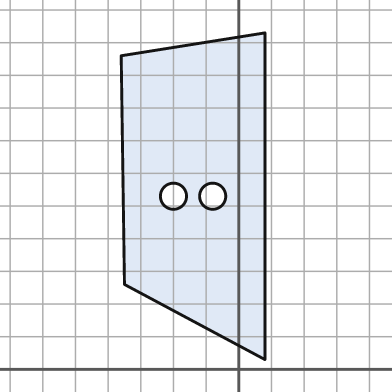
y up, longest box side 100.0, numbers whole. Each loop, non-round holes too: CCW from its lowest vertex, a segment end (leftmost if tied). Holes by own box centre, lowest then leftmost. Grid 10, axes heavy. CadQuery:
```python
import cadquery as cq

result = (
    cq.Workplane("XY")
    .moveTo(8.0, 3.0)
    .lineTo(8.0, 103.0)
    .lineTo(-36.0, 96.0)
    .lineTo(-35.0, 26.0)
    .close()
    .moveTo(-20.0, 53.0)
    .circle(4.0)
    .moveTo(-8.0, 53.0)
    .circle(4.0)
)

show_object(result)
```